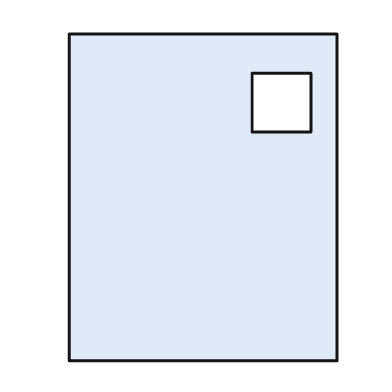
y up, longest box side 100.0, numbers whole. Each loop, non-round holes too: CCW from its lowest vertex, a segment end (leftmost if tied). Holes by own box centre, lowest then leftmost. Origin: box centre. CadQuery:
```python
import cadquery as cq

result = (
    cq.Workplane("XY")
    .moveTo(-41.0, -50.0)
    .lineTo(41.0, -50.0)
    .lineTo(41.0, 50.0)
    .lineTo(-41.0, 50.0)
    .close()
    .moveTo(15.0, 20.0)
    .lineTo(33.0, 20.0)
    .lineTo(33.0, 38.0)
    .lineTo(15.0, 38.0)
    .close()
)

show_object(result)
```